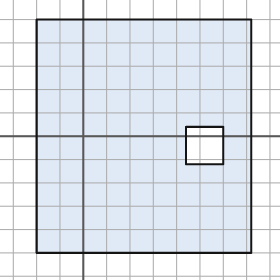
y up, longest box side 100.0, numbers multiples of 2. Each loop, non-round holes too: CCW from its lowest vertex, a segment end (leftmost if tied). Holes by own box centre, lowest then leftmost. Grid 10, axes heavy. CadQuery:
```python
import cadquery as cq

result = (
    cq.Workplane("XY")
    .moveTo(-20.0, -50.0)
    .lineTo(72.0, -50.0)
    .lineTo(72.0, 50.0)
    .lineTo(-20.0, 50.0)
    .close()
    .moveTo(44.0, -12.0)
    .lineTo(60.0, -12.0)
    .lineTo(60.0, 4.0)
    .lineTo(44.0, 4.0)
    .close()
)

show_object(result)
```